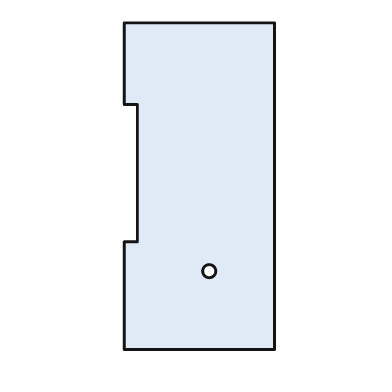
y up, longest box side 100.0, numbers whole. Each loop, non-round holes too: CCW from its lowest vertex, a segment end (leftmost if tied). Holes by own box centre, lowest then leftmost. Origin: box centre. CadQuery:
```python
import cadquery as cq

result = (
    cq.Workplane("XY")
    .moveTo(-23.0, -50.0)
    .lineTo(23.0, -50.0)
    .lineTo(23.0, 50.0)
    .lineTo(-23.0, 50.0)
    .lineTo(-23.0, 25.0)
    .lineTo(-19.0, 25.0)
    .lineTo(-19.0, -17.0)
    .lineTo(-23.0, -17.0)
    .close()
    .moveTo(3.0, -26.0)
    .circle(2.0)
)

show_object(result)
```